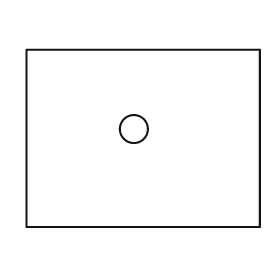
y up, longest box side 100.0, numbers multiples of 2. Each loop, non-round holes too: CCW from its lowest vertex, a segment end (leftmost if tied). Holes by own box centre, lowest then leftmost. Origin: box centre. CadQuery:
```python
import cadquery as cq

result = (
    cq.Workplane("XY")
    .moveTo(-50.0, -38.0)
    .lineTo(50.0, -38.0)
    .lineTo(50.0, 38.0)
    .lineTo(-50.0, 38.0)
    .close()
    .moveTo(-4.0, 4.0)
    .circle(6.0)
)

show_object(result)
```